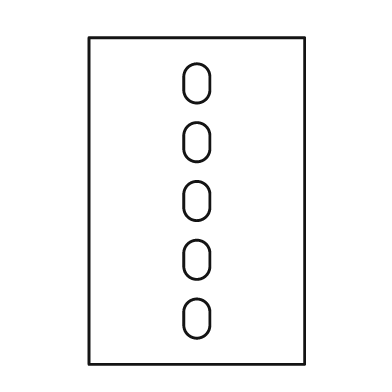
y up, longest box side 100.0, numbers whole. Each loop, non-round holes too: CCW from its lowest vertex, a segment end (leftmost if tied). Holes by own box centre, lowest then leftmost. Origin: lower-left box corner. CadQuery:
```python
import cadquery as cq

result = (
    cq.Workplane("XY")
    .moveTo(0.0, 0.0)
    .lineTo(66.0, 0.0)
    .lineTo(66.0, 100.0)
    .lineTo(0.0, 100.0)
    .close()
    .moveTo(29.0, 12.0)
    .threePointArc((33.0, 8.0), (37.0, 12.0))
    .lineTo(37.0, 16.0)
    .threePointArc((33.0, 20.0), (29.0, 16.0))
    .close()
    .moveTo(29.0, 30.0)
    .threePointArc((33.0, 26.0), (37.0, 30.0))
    .lineTo(37.0, 34.0)
    .threePointArc((33.0, 38.0), (29.0, 34.0))
    .close()
    .moveTo(29.0, 48.0)
    .threePointArc((33.0, 44.0), (37.0, 48.0))
    .lineTo(37.0, 52.0)
    .threePointArc((33.0, 56.0), (29.0, 52.0))
    .close()
    .moveTo(29.0, 66.0)
    .threePointArc((33.0, 62.0), (37.0, 66.0))
    .lineTo(37.0, 70.0)
    .threePointArc((33.0, 74.0), (29.0, 70.0))
    .close()
    .moveTo(29.0, 84.0)
    .threePointArc((33.0, 80.0), (37.0, 84.0))
    .lineTo(37.0, 88.0)
    .threePointArc((33.0, 92.0), (29.0, 88.0))
    .close()
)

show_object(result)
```